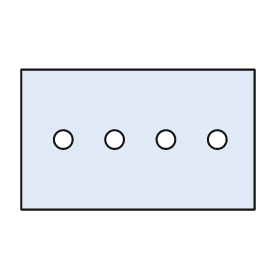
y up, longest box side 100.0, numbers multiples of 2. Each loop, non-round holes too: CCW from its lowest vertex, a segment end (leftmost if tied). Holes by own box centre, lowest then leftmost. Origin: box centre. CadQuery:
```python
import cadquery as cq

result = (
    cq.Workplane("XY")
    .moveTo(-50.0, -30.0)
    .lineTo(50.0, -30.0)
    .lineTo(50.0, 30.0)
    .lineTo(-50.0, 30.0)
    .close()
    .moveTo(-32.0, 0.0)
    .circle(4.0)
    .moveTo(-10.0, 0.0)
    .circle(4.0)
    .moveTo(12.0, 0.0)
    .circle(4.0)
    .moveTo(34.0, 0.0)
    .circle(4.0)
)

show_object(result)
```